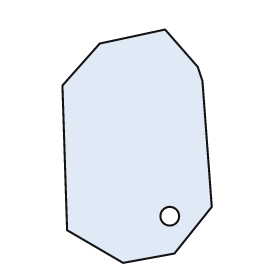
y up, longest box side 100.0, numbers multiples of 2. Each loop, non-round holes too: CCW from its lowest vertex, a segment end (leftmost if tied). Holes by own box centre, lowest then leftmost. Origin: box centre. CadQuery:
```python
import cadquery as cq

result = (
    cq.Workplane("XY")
    .moveTo(-6.0, -50.0)
    .lineTo(16.0, -46.0)
    .lineTo(32.0, -26.0)
    .lineTo(28.0, 28.0)
    .lineTo(26.0, 34.0)
    .lineTo(12.0, 50.0)
    .lineTo(-16.0, 44.0)
    .lineTo(-32.0, 26.0)
    .lineTo(-30.0, -36.0)
    .close()
    .moveTo(14.0, -30.0)
    .circle(4.0)
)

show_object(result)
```